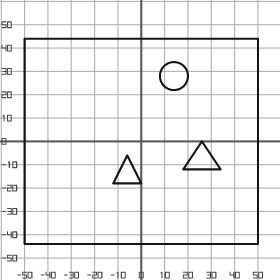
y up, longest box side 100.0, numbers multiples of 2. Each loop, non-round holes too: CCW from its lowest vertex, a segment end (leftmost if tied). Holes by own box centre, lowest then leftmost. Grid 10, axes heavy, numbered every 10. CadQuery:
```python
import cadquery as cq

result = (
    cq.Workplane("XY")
    .moveTo(-50.0, -44.0)
    .lineTo(50.0, -44.0)
    .lineTo(50.0, 44.0)
    .lineTo(-50.0, 44.0)
    .close()
    .moveTo(-12.0, -18.0)
    .lineTo(0.0, -18.0)
    .lineTo(-6.0, -6.0)
    .close()
    .moveTo(18.0, -12.0)
    .lineTo(34.0, -12.0)
    .lineTo(26.0, 0.0)
    .close()
    .moveTo(14.0, 28.0)
    .circle(6.0)
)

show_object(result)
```